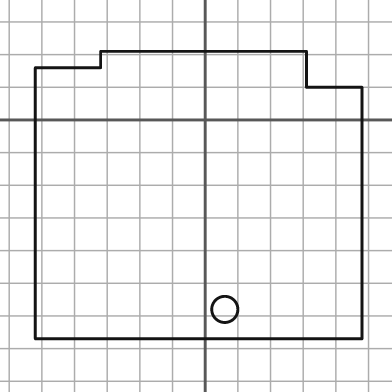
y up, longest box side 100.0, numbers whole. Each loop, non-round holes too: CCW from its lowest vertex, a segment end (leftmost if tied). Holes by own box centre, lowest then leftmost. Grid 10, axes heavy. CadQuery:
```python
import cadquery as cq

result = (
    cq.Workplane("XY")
    .moveTo(-52.0, -67.0)
    .lineTo(48.0, -67.0)
    .lineTo(48.0, 10.0)
    .lineTo(31.0, 10.0)
    .lineTo(31.0, 21.0)
    .lineTo(-32.0, 21.0)
    .lineTo(-32.0, 16.0)
    .lineTo(-52.0, 16.0)
    .close()
    .moveTo(6.0, -58.0)
    .circle(4.0)
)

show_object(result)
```